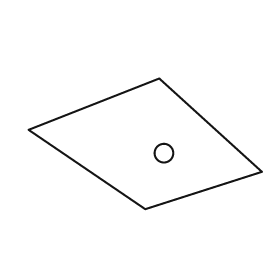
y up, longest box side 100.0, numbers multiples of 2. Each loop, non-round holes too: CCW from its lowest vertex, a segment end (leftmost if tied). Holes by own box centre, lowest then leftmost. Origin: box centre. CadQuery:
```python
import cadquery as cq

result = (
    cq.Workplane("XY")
    .moveTo(0.0, -28.0)
    .lineTo(50.0, -12.0)
    .lineTo(6.0, 28.0)
    .lineTo(-50.0, 6.0)
    .close()
    .moveTo(8.0, -4.0)
    .circle(4.0)
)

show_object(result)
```